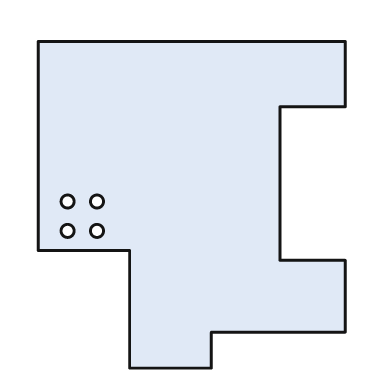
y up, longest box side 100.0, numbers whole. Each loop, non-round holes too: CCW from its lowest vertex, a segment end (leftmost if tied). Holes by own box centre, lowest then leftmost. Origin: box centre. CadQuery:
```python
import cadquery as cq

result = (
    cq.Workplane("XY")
    .moveTo(-19.0, -50.0)
    .lineTo(6.0, -50.0)
    .lineTo(6.0, -39.0)
    .lineTo(47.0, -39.0)
    .lineTo(47.0, -17.0)
    .lineTo(27.0, -17.0)
    .lineTo(27.0, 30.0)
    .lineTo(47.0, 30.0)
    .lineTo(47.0, 50.0)
    .lineTo(-47.0, 50.0)
    .lineTo(-47.0, -14.0)
    .lineTo(-19.0, -14.0)
    .close()
    .moveTo(-38.0, -8.0)
    .circle(2.0)
    .moveTo(-29.0, -8.0)
    .circle(2.0)
    .moveTo(-38.0, 1.0)
    .circle(2.0)
    .moveTo(-29.0, 1.0)
    .circle(2.0)
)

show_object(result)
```